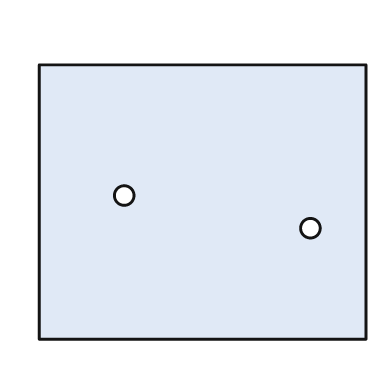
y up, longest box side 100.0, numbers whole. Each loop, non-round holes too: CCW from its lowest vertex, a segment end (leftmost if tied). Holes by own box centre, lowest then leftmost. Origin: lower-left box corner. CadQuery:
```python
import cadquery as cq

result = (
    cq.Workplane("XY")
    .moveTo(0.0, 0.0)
    .lineTo(100.0, 0.0)
    .lineTo(100.0, 84.0)
    .lineTo(0.0, 84.0)
    .close()
    .moveTo(83.0, 34.0)
    .circle(3.0)
    .moveTo(26.0, 44.0)
    .circle(3.0)
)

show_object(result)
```